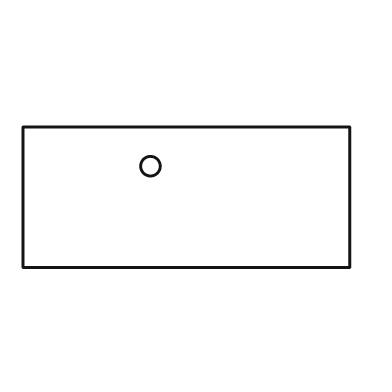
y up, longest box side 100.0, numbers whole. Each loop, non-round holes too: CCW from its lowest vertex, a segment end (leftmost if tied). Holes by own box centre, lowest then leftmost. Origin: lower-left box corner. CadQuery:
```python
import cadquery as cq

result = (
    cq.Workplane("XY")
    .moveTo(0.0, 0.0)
    .lineTo(100.0, 0.0)
    .lineTo(100.0, 43.0)
    .lineTo(0.0, 43.0)
    .close()
    .moveTo(39.0, 31.0)
    .circle(3.0)
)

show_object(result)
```